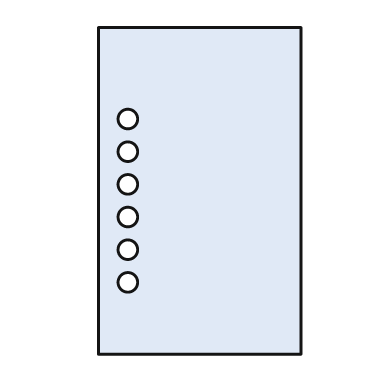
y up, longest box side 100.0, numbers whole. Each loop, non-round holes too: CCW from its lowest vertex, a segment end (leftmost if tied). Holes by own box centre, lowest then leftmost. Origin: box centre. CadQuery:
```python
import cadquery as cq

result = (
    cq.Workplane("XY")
    .moveTo(-31.0, -50.0)
    .lineTo(31.0, -50.0)
    .lineTo(31.0, 50.0)
    .lineTo(-31.0, 50.0)
    .close()
    .moveTo(-22.0, -28.0)
    .circle(3.0)
    .moveTo(-22.0, -18.0)
    .circle(3.0)
    .moveTo(-22.0, -8.0)
    .circle(3.0)
    .moveTo(-22.0, 2.0)
    .circle(3.0)
    .moveTo(-22.0, 12.0)
    .circle(3.0)
    .moveTo(-22.0, 22.0)
    .circle(3.0)
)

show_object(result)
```